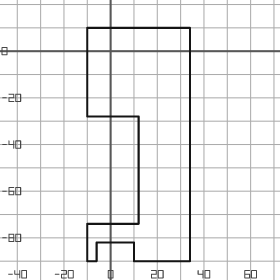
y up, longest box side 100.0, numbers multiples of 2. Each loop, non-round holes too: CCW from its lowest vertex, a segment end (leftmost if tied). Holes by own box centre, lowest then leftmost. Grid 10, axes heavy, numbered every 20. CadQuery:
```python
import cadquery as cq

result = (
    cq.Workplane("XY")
    .moveTo(-10.0, -90.0)
    .lineTo(-6.0, -90.0)
    .lineTo(-6.0, -82.0)
    .lineTo(10.0, -82.0)
    .lineTo(10.0, -90.0)
    .lineTo(34.0, -90.0)
    .lineTo(34.0, 10.0)
    .lineTo(-10.0, 10.0)
    .lineTo(-10.0, -28.0)
    .lineTo(12.0, -28.0)
    .lineTo(12.0, -74.0)
    .lineTo(-10.0, -74.0)
    .close()
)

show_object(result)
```